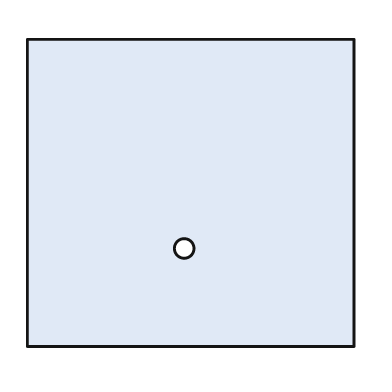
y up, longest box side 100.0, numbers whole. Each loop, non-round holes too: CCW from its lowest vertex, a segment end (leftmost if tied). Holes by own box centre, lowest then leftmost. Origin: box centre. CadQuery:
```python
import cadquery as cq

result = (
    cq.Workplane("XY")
    .moveTo(-50.0, -47.0)
    .lineTo(50.0, -47.0)
    .lineTo(50.0, 47.0)
    .lineTo(-50.0, 47.0)
    .close()
    .moveTo(-2.0, -17.0)
    .circle(3.0)
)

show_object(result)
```